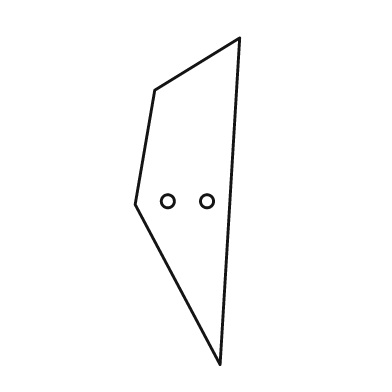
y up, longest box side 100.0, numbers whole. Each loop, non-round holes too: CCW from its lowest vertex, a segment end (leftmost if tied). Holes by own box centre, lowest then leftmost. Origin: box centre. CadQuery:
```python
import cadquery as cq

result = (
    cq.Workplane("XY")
    .moveTo(10.0, -50.0)
    .lineTo(16.0, 50.0)
    .lineTo(-10.0, 34.0)
    .lineTo(-16.0, -1.0)
    .close()
    .moveTo(-6.0, 0.0)
    .circle(2.0)
    .moveTo(6.0, 0.0)
    .circle(2.0)
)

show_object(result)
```